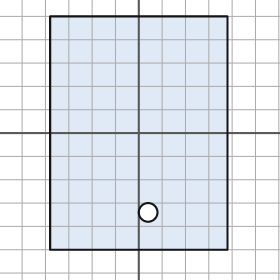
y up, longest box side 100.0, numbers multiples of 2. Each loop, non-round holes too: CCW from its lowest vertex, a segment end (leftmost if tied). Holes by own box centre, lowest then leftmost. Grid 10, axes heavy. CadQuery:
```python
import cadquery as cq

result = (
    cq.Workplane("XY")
    .moveTo(-38.0, -50.0)
    .lineTo(38.0, -50.0)
    .lineTo(38.0, 50.0)
    .lineTo(-38.0, 50.0)
    .close()
    .moveTo(4.0, -34.0)
    .circle(4.0)
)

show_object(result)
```